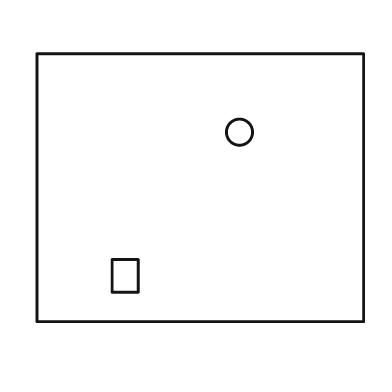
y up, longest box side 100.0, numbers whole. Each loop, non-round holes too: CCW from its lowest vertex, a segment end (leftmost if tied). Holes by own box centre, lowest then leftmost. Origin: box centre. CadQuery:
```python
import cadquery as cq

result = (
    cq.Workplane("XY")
    .moveTo(-50.0, -41.0)
    .lineTo(50.0, -41.0)
    .lineTo(50.0, 41.0)
    .lineTo(-50.0, 41.0)
    .close()
    .moveTo(-27.0, -32.0)
    .lineTo(-19.0, -32.0)
    .lineTo(-19.0, -22.0)
    .lineTo(-27.0, -22.0)
    .close()
    .moveTo(12.0, 17.0)
    .circle(4.0)
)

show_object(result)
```